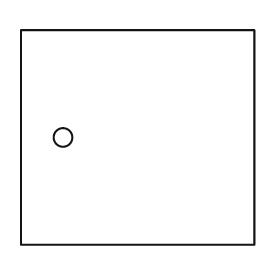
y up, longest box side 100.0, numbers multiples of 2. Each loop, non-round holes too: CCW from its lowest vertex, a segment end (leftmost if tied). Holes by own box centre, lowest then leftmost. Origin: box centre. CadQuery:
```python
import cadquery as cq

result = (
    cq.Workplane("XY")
    .moveTo(-50.0, -46.0)
    .lineTo(50.0, -46.0)
    .lineTo(50.0, 46.0)
    .lineTo(-50.0, 46.0)
    .close()
    .moveTo(-32.0, 0.0)
    .circle(4.0)
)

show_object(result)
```